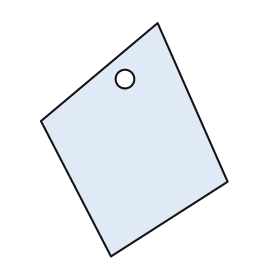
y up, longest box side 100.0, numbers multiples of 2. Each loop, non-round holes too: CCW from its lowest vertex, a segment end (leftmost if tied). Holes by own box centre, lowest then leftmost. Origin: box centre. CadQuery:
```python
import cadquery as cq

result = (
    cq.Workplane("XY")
    .moveTo(-10.0, -50.0)
    .lineTo(40.0, -18.0)
    .lineTo(10.0, 50.0)
    .lineTo(-40.0, 8.0)
    .close()
    .moveTo(-4.0, 26.0)
    .circle(4.0)
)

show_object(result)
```